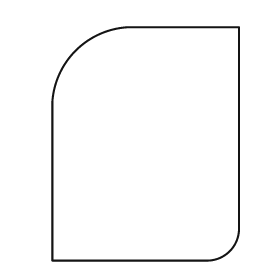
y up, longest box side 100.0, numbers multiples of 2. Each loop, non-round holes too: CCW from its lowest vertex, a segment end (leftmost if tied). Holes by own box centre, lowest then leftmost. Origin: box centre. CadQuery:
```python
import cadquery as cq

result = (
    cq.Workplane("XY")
    .moveTo(-40.0, -50.0)
    .lineTo(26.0, -50.0)
    .threePointArc((36.0, -46.0), (40.0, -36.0))
    .lineTo(40.0, 50.0)
    .lineTo(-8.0, 50.0)
    .threePointArc((-30.0, 40.0), (-40.0, 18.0))
    .close()
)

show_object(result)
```